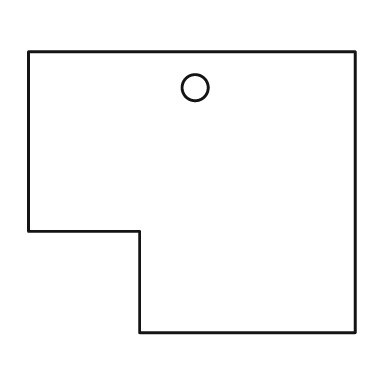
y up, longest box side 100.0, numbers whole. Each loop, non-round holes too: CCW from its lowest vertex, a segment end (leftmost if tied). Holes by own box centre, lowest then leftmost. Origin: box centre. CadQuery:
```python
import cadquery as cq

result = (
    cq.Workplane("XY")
    .moveTo(-16.0, -43.0)
    .lineTo(50.0, -43.0)
    .lineTo(50.0, 43.0)
    .lineTo(-50.0, 43.0)
    .lineTo(-50.0, -12.0)
    .lineTo(-16.0, -12.0)
    .close()
    .moveTo(1.0, 32.0)
    .circle(4.0)
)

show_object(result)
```